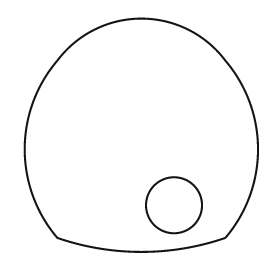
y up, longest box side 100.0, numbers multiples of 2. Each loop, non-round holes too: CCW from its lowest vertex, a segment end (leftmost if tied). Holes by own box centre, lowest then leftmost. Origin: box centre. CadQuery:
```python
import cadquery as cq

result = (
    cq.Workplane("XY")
    .moveTo(-36.0, -44.0)
    .threePointArc((0.0, -50.0), (36.0, -44.0))
    .threePointArc((50.0, -6.0), (36.0, 32.0))
    .threePointArc((0.0, 50.0), (-36.0, 32.0))
    .threePointArc((-50.0, -6.0), (-36.0, -44.0))
    .close()
    .moveTo(14.0, -30.0)
    .circle(12.0)
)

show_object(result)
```